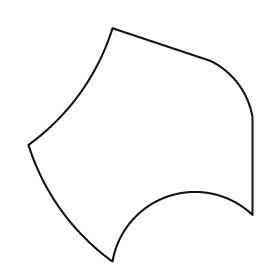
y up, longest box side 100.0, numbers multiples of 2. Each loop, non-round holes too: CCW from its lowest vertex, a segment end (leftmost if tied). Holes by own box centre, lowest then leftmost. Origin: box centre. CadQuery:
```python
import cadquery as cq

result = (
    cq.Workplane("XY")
    .moveTo(-12.0, -50.0)
    .threePointArc((12.0, -22.0), (48.0, -30.0))
    .lineTo(48.0, 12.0)
    .threePointArc((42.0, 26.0), (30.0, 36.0))
    .lineTo(-12.0, 50.0)
    .threePointArc((-26.0, 22.0), (-48.0, 0.0))
    .threePointArc((-34.0, -28.0), (-12.0, -50.0))
    .close()
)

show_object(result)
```